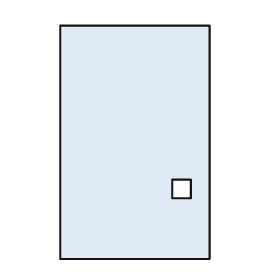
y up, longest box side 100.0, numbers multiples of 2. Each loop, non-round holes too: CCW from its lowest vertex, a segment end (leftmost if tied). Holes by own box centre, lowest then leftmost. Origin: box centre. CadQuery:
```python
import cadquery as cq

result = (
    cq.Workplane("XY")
    .moveTo(-32.0, -50.0)
    .lineTo(32.0, -50.0)
    .lineTo(32.0, 50.0)
    .lineTo(-32.0, 50.0)
    .close()
    .moveTo(16.0, -24.0)
    .lineTo(24.0, -24.0)
    .lineTo(24.0, -16.0)
    .lineTo(16.0, -16.0)
    .close()
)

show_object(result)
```